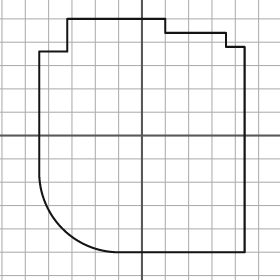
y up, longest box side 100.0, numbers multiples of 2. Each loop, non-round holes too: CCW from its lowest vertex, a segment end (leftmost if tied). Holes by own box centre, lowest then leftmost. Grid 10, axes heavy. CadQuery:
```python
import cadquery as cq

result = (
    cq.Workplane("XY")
    .moveTo(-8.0, -50.0)
    .lineTo(44.0, -50.0)
    .lineTo(44.0, 38.0)
    .lineTo(36.0, 38.0)
    .lineTo(36.0, 44.0)
    .lineTo(10.0, 44.0)
    .lineTo(10.0, 50.0)
    .lineTo(-32.0, 50.0)
    .lineTo(-32.0, 36.0)
    .lineTo(-44.0, 36.0)
    .lineTo(-44.0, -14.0)
    .threePointArc((-34.0, -40.0), (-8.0, -50.0))
    .close()
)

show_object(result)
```